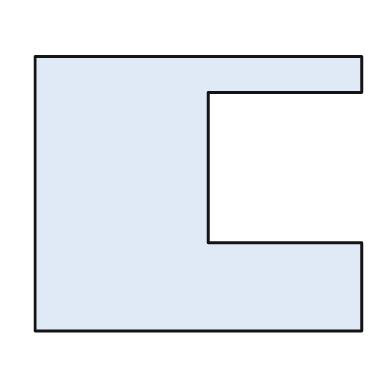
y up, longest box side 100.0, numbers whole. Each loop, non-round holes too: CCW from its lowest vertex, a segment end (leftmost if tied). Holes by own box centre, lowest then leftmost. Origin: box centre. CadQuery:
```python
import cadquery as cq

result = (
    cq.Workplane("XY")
    .moveTo(-50.0, -42.0)
    .lineTo(50.0, -42.0)
    .lineTo(50.0, -15.0)
    .lineTo(3.0, -15.0)
    .lineTo(3.0, 31.0)
    .lineTo(50.0, 31.0)
    .lineTo(50.0, 42.0)
    .lineTo(-50.0, 42.0)
    .close()
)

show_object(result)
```